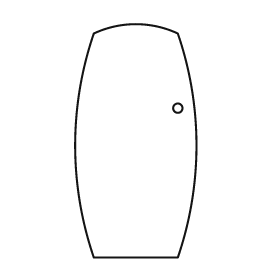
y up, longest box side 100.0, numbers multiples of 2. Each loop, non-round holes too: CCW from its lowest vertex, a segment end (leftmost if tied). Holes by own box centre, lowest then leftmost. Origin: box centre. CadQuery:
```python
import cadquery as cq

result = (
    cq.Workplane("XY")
    .moveTo(-18.0, -50.0)
    .lineTo(18.0, -50.0)
    .threePointArc((26.0, -2.0), (18.0, 46.0))
    .threePointArc((0.0, 50.0), (-18.0, 46.0))
    .threePointArc((-26.0, -2.0), (-18.0, -50.0))
    .close()
    .moveTo(18.0, 14.0)
    .circle(2.0)
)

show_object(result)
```